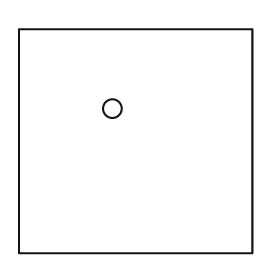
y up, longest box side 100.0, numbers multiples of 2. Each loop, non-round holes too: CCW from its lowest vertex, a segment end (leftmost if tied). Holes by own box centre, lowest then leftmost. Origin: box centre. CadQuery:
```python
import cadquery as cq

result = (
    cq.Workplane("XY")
    .moveTo(-50.0, -48.0)
    .lineTo(50.0, -48.0)
    .lineTo(50.0, 48.0)
    .lineTo(-50.0, 48.0)
    .close()
    .moveTo(-10.0, 14.0)
    .circle(4.0)
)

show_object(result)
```